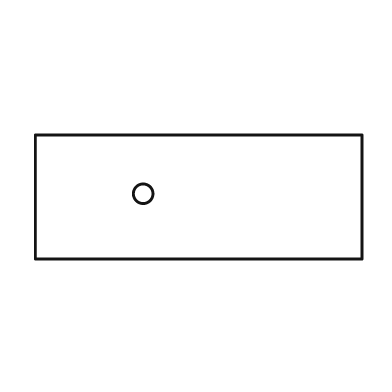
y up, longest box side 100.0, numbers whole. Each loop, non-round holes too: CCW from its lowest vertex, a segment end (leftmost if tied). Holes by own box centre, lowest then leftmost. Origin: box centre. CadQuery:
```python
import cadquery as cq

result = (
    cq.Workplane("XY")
    .moveTo(-50.0, -19.0)
    .lineTo(50.0, -19.0)
    .lineTo(50.0, 19.0)
    .lineTo(-50.0, 19.0)
    .close()
    .moveTo(-17.0, 1.0)
    .circle(3.0)
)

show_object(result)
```